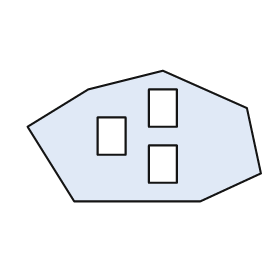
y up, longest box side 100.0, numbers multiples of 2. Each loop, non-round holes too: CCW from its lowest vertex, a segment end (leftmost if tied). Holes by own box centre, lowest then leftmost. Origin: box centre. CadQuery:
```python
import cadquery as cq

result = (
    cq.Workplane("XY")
    .moveTo(-30.0, -28.0)
    .lineTo(24.0, -28.0)
    .lineTo(50.0, -16.0)
    .lineTo(44.0, 12.0)
    .lineTo(8.0, 28.0)
    .lineTo(-24.0, 20.0)
    .lineTo(-50.0, 4.0)
    .close()
    .moveTo(2.0, -20.0)
    .lineTo(14.0, -20.0)
    .lineTo(14.0, -4.0)
    .lineTo(2.0, -4.0)
    .close()
    .moveTo(-20.0, -8.0)
    .lineTo(-8.0, -8.0)
    .lineTo(-8.0, 8.0)
    .lineTo(-20.0, 8.0)
    .close()
    .moveTo(2.0, 4.0)
    .lineTo(14.0, 4.0)
    .lineTo(14.0, 20.0)
    .lineTo(2.0, 20.0)
    .close()
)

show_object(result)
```